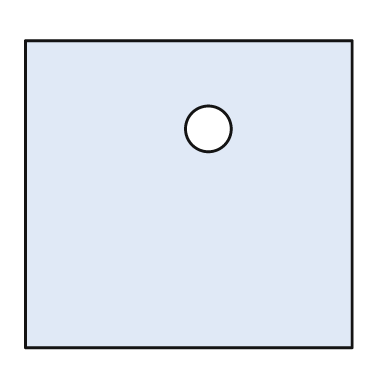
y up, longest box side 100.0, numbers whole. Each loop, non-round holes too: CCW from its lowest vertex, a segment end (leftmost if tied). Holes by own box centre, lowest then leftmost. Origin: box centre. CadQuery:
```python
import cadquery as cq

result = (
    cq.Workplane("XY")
    .moveTo(-50.0, -47.0)
    .lineTo(50.0, -47.0)
    .lineTo(50.0, 47.0)
    .lineTo(-50.0, 47.0)
    .close()
    .moveTo(6.0, 20.0)
    .circle(7.0)
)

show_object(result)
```